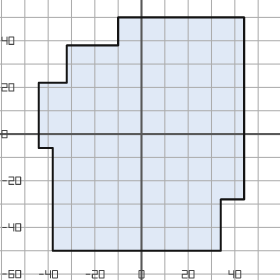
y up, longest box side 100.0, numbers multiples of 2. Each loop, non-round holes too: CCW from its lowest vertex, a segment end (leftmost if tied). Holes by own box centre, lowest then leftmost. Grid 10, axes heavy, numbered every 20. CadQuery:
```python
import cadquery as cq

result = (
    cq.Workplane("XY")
    .moveTo(-38.0, -50.0)
    .lineTo(34.0, -50.0)
    .lineTo(34.0, -28.0)
    .lineTo(44.0, -28.0)
    .lineTo(44.0, 50.0)
    .lineTo(-10.0, 50.0)
    .lineTo(-10.0, 38.0)
    .lineTo(-32.0, 38.0)
    .lineTo(-32.0, 22.0)
    .lineTo(-44.0, 22.0)
    .lineTo(-44.0, -6.0)
    .lineTo(-38.0, -6.0)
    .close()
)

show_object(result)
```